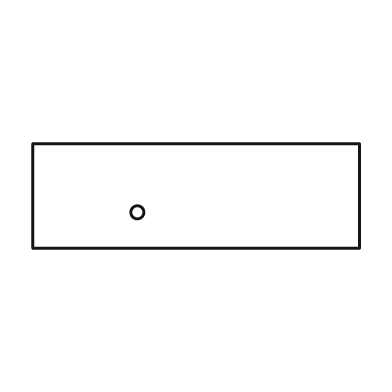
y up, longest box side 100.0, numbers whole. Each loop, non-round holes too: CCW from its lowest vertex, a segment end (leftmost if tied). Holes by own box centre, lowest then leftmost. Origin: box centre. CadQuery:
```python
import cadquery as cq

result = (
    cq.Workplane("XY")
    .moveTo(-50.0, -16.0)
    .lineTo(50.0, -16.0)
    .lineTo(50.0, 16.0)
    .lineTo(-50.0, 16.0)
    .close()
    .moveTo(-18.0, -5.0)
    .circle(2.0)
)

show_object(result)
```